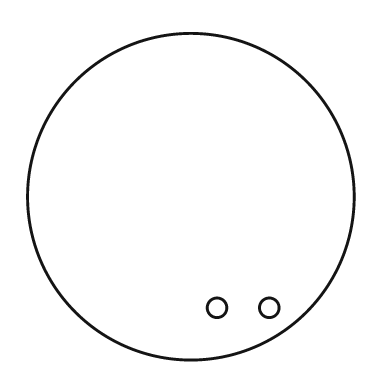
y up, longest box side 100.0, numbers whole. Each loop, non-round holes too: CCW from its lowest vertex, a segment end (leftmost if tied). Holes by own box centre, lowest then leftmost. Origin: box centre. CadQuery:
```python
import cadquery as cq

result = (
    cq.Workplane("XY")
    .moveTo(0.0, 0.0)
    .circle(50.0)
    .moveTo(8.0, -34.0)
    .circle(3.0)
    .moveTo(24.0, -34.0)
    .circle(3.0)
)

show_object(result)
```